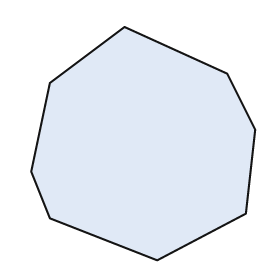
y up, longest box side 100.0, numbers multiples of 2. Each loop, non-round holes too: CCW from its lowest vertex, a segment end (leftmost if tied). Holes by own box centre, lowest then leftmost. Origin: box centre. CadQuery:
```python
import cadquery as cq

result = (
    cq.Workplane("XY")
    .moveTo(6.0, -50.0)
    .lineTo(44.0, -30.0)
    .lineTo(48.0, 6.0)
    .lineTo(36.0, 30.0)
    .lineTo(-8.0, 50.0)
    .lineTo(-40.0, 26.0)
    .lineTo(-48.0, -12.0)
    .lineTo(-40.0, -32.0)
    .close()
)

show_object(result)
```